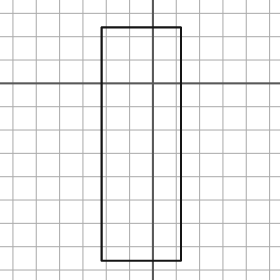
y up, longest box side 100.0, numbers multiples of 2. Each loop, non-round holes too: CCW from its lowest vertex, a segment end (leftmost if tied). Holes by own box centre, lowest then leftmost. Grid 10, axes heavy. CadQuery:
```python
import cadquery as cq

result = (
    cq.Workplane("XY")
    .moveTo(-22.0, -76.0)
    .lineTo(12.0, -76.0)
    .lineTo(12.0, 24.0)
    .lineTo(-22.0, 24.0)
    .close()
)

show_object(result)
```